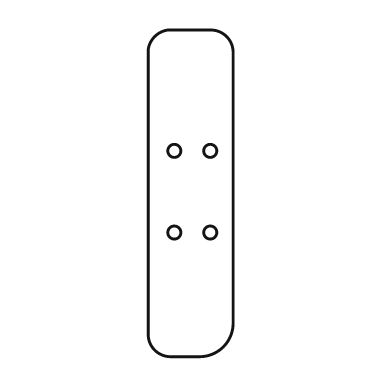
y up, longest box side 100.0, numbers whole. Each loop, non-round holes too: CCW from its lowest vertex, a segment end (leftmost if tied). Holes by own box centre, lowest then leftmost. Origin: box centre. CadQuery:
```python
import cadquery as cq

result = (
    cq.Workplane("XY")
    .moveTo(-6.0, -50.0)
    .lineTo(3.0, -50.0)
    .threePointArc((10.0, -47.0), (13.0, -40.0))
    .lineTo(13.0, 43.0)
    .threePointArc((11.0, 48.0), (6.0, 50.0))
    .lineTo(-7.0, 50.0)
    .threePointArc((-11.0, 48.0), (-13.0, 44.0))
    .lineTo(-13.0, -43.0)
    .threePointArc((-11.0, -48.0), (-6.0, -50.0))
    .close()
    .moveTo(-5.0, -12.0)
    .circle(2.0)
    .moveTo(6.0, -12.0)
    .circle(2.0)
    .moveTo(-5.0, 13.0)
    .circle(2.0)
    .moveTo(6.0, 13.0)
    .circle(2.0)
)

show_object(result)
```